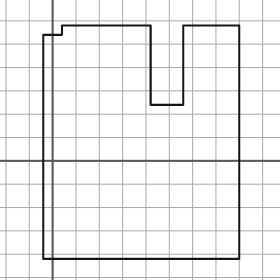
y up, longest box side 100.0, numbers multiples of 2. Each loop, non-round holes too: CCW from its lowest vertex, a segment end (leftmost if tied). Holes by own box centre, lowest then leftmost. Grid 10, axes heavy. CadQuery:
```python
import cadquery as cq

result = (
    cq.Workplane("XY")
    .moveTo(-4.0, -42.0)
    .lineTo(80.0, -42.0)
    .lineTo(80.0, 58.0)
    .lineTo(56.0, 58.0)
    .lineTo(56.0, 24.0)
    .lineTo(42.0, 24.0)
    .lineTo(42.0, 58.0)
    .lineTo(4.0, 58.0)
    .lineTo(4.0, 54.0)
    .lineTo(-4.0, 54.0)
    .close()
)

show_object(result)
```